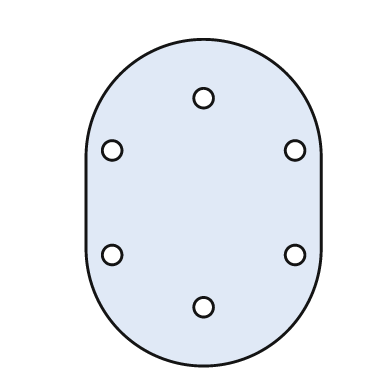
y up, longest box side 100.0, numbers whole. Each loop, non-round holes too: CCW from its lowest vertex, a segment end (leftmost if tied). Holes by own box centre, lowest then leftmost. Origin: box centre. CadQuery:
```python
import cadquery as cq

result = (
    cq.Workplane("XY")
    .moveTo(-36.0, -14.0)
    .threePointArc((0.0, -50.0), (36.0, -14.0))
    .lineTo(36.0, 14.0)
    .threePointArc((0.0, 50.0), (-36.0, 14.0))
    .close()
    .moveTo(0.0, -32.0)
    .circle(3.0)
    .moveTo(-28.0, -16.0)
    .circle(3.0)
    .moveTo(28.0, -16.0)
    .circle(3.0)
    .moveTo(-28.0, 16.0)
    .circle(3.0)
    .moveTo(28.0, 16.0)
    .circle(3.0)
    .moveTo(0.0, 32.0)
    .circle(3.0)
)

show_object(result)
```